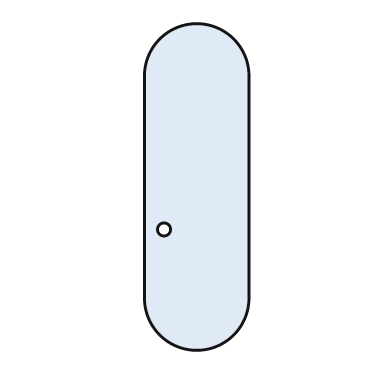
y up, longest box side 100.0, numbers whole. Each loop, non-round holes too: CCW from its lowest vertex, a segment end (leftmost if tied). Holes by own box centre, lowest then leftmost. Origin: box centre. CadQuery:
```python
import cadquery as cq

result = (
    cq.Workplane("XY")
    .moveTo(-16.0, -34.0)
    .threePointArc((0.0, -50.0), (16.0, -34.0))
    .lineTo(16.0, 34.0)
    .threePointArc((0.0, 50.0), (-16.0, 34.0))
    .close()
    .moveTo(-10.0, -13.0)
    .circle(2.0)
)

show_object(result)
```